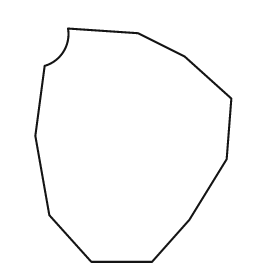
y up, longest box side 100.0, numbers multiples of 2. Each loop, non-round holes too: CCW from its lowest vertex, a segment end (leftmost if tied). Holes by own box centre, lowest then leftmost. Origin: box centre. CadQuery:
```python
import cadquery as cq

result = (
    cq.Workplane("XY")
    .moveTo(-18.0, -50.0)
    .lineTo(8.0, -50.0)
    .lineTo(24.0, -32.0)
    .lineTo(40.0, -6.0)
    .lineTo(42.0, 20.0)
    .lineTo(22.0, 38.0)
    .lineTo(2.0, 48.0)
    .lineTo(-28.0, 50.0)
    .threePointArc((-30.0, 40.0), (-38.0, 34.0))
    .lineTo(-42.0, 4.0)
    .lineTo(-36.0, -30.0)
    .close()
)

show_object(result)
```